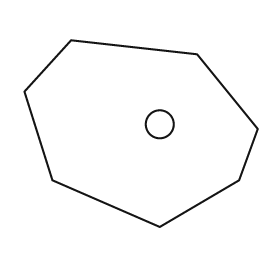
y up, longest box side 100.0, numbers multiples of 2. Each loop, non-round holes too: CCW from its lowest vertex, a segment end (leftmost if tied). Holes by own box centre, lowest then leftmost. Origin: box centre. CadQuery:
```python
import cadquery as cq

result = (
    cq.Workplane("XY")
    .moveTo(8.0, -40.0)
    .lineTo(42.0, -20.0)
    .lineTo(50.0, 2.0)
    .lineTo(24.0, 34.0)
    .lineTo(-30.0, 40.0)
    .lineTo(-50.0, 18.0)
    .lineTo(-38.0, -20.0)
    .close()
    .moveTo(8.0, 4.0)
    .circle(6.0)
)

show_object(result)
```